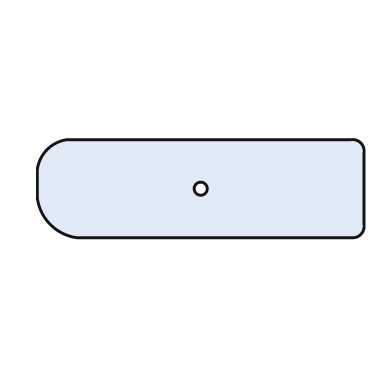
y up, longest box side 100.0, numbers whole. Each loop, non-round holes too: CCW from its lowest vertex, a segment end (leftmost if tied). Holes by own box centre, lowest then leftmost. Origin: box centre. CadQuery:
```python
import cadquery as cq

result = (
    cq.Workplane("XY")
    .moveTo(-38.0, -15.0)
    .lineTo(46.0, -15.0)
    .threePointArc((49.0, -14.0), (50.0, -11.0))
    .lineTo(50.0, 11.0)
    .threePointArc((49.0, 14.0), (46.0, 15.0))
    .lineTo(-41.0, 15.0)
    .threePointArc((-47.0, 12.0), (-50.0, 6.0))
    .lineTo(-50.0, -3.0)
    .threePointArc((-46.0, -11.0), (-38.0, -15.0))
    .close()
    .moveTo(0.0, 0.0)
    .circle(2.0)
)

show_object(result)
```